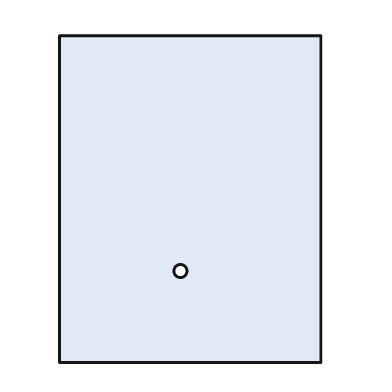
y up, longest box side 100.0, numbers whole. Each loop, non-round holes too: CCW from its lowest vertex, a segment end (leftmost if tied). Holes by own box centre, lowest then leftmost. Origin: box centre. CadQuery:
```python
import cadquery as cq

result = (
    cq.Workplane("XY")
    .moveTo(-40.0, -50.0)
    .lineTo(40.0, -50.0)
    .lineTo(40.0, 50.0)
    .lineTo(-40.0, 50.0)
    .close()
    .moveTo(-3.0, -22.0)
    .circle(2.0)
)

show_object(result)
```